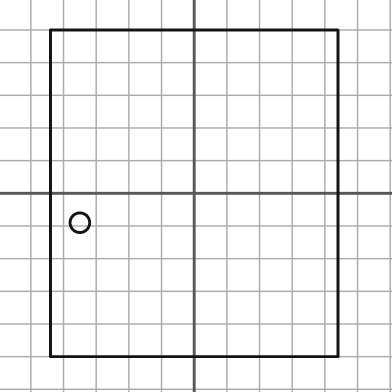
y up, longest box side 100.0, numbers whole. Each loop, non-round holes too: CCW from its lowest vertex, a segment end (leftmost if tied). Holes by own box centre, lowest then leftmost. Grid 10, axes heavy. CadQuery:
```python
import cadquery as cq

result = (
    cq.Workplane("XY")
    .moveTo(-44.0, -50.0)
    .lineTo(44.0, -50.0)
    .lineTo(44.0, 50.0)
    .lineTo(-44.0, 50.0)
    .close()
    .moveTo(-35.0, -9.0)
    .circle(3.0)
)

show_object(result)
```